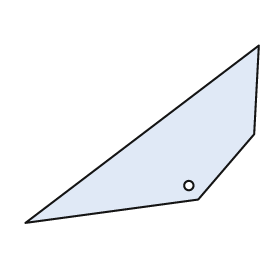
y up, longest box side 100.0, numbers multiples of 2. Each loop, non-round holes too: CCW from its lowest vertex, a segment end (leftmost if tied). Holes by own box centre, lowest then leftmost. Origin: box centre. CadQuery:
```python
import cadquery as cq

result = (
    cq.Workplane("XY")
    .moveTo(-50.0, -38.0)
    .lineTo(24.0, -28.0)
    .lineTo(48.0, 0.0)
    .lineTo(50.0, 38.0)
    .close()
    .moveTo(20.0, -22.0)
    .circle(2.0)
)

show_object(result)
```